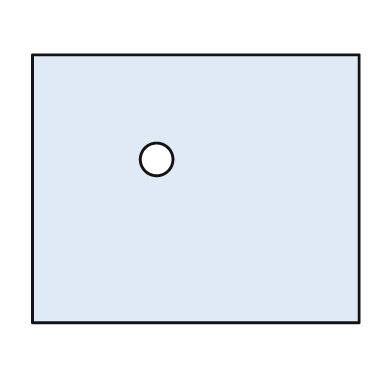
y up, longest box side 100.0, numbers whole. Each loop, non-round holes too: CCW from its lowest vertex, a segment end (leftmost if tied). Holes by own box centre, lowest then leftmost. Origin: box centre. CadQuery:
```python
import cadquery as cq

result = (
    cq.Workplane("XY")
    .moveTo(-50.0, -41.0)
    .lineTo(50.0, -41.0)
    .lineTo(50.0, 41.0)
    .lineTo(-50.0, 41.0)
    .close()
    .moveTo(-12.0, 9.0)
    .circle(5.0)
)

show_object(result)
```